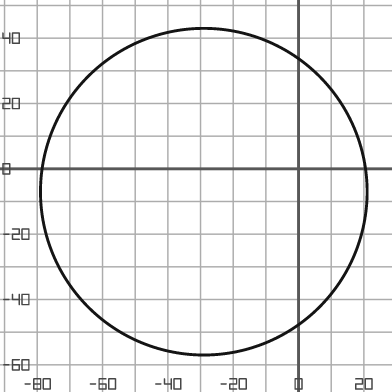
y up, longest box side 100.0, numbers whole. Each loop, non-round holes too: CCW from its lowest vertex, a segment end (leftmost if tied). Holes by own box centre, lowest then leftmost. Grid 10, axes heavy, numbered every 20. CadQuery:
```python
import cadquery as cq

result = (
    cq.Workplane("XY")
    .moveTo(-29.0, -7.0)
    .circle(50.0)
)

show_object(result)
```